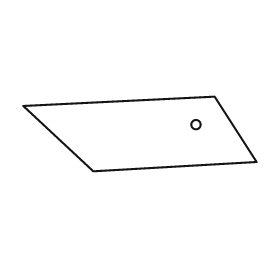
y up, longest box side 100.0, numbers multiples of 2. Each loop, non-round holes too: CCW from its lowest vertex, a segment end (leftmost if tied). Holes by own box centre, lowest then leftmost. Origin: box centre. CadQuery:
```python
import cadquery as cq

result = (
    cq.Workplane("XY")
    .moveTo(-20.0, -16.0)
    .lineTo(50.0, -12.0)
    .lineTo(32.0, 16.0)
    .lineTo(-50.0, 12.0)
    .close()
    .moveTo(24.0, 4.0)
    .circle(2.0)
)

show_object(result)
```